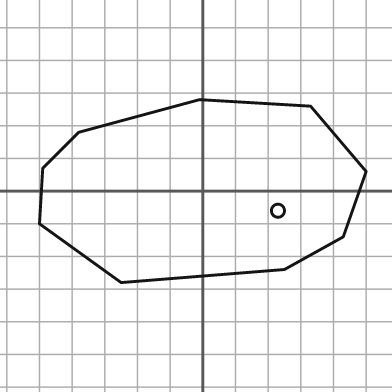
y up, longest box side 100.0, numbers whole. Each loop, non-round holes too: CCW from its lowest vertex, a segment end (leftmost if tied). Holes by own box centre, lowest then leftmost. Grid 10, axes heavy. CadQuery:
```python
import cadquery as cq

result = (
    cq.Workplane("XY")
    .moveTo(-25.0, -28.0)
    .lineTo(25.0, -24.0)
    .lineTo(43.0, -14.0)
    .lineTo(50.0, 6.0)
    .lineTo(33.0, 26.0)
    .lineTo(-1.0, 28.0)
    .lineTo(-38.0, 18.0)
    .lineTo(-49.0, 7.0)
    .lineTo(-50.0, -10.0)
    .close()
    .moveTo(23.0, -6.0)
    .circle(2.0)
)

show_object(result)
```